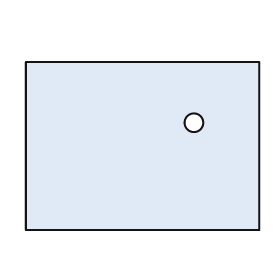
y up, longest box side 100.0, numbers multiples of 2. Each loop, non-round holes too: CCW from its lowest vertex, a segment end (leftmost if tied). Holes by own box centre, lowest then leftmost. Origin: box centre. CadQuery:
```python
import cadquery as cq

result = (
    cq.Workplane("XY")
    .moveTo(-50.0, -36.0)
    .lineTo(50.0, -36.0)
    .lineTo(50.0, 36.0)
    .lineTo(-50.0, 36.0)
    .close()
    .moveTo(22.0, 10.0)
    .circle(4.0)
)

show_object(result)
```